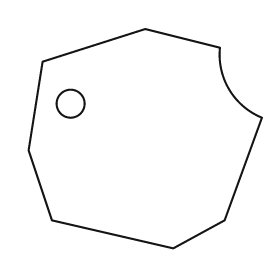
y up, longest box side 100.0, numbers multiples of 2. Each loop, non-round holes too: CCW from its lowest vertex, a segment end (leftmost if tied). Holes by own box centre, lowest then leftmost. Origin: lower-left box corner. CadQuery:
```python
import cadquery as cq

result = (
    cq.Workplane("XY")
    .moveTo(62.0, 0.0)
    .lineTo(84.0, 12.0)
    .lineTo(100.0, 56.0)
    .threePointArc((86.0, 68.0), (82.0, 86.0))
    .lineTo(50.0, 94.0)
    .lineTo(6.0, 80.0)
    .lineTo(0.0, 42.0)
    .lineTo(10.0, 12.0)
    .close()
    .moveTo(18.0, 62.0)
    .circle(6.0)
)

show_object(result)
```